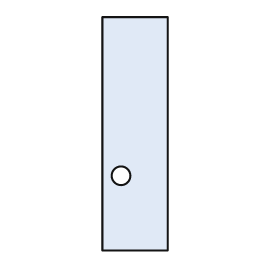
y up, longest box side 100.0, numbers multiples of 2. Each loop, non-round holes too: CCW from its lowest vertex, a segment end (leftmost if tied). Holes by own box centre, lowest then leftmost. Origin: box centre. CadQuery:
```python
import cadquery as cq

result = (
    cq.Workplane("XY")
    .moveTo(-14.0, -50.0)
    .lineTo(14.0, -50.0)
    .lineTo(14.0, 50.0)
    .lineTo(-14.0, 50.0)
    .close()
    .moveTo(-6.0, -18.0)
    .circle(4.0)
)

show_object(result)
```